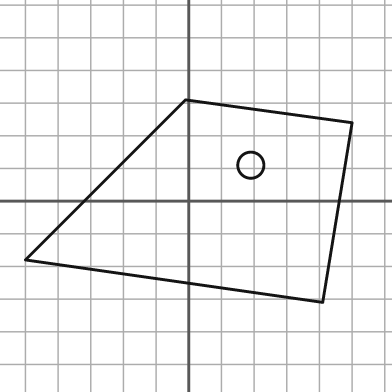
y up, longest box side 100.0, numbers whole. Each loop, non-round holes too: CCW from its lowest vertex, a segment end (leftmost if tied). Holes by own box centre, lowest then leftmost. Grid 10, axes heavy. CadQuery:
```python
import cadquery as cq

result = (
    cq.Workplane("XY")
    .moveTo(41.0, -31.0)
    .lineTo(50.0, 24.0)
    .lineTo(-1.0, 31.0)
    .lineTo(-50.0, -18.0)
    .close()
    .moveTo(19.0, 11.0)
    .circle(4.0)
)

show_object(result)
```